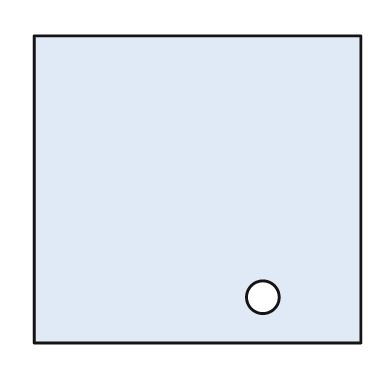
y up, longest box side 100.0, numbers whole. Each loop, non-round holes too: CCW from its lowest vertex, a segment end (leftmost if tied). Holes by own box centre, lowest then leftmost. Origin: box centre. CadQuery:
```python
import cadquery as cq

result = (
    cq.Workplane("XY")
    .moveTo(-50.0, -47.0)
    .lineTo(50.0, -47.0)
    .lineTo(50.0, 47.0)
    .lineTo(-50.0, 47.0)
    .close()
    .moveTo(20.0, -33.0)
    .circle(5.0)
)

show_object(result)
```